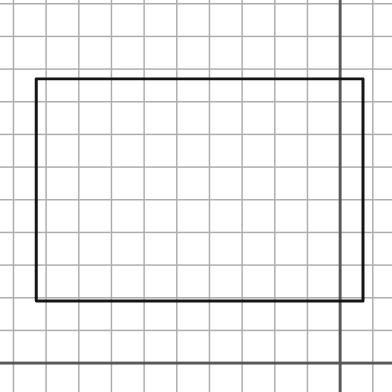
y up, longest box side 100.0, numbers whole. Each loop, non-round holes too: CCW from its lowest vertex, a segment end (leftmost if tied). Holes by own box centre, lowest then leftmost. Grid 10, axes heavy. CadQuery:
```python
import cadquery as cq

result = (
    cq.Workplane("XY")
    .moveTo(-93.0, 19.0)
    .lineTo(7.0, 19.0)
    .lineTo(7.0, 87.0)
    .lineTo(-93.0, 87.0)
    .close()
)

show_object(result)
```